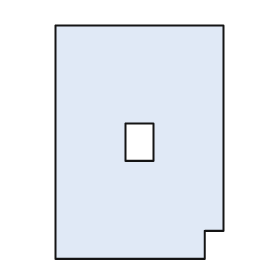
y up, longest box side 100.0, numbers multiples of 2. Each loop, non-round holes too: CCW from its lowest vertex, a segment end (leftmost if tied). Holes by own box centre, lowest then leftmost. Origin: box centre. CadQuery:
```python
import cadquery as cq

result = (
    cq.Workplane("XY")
    .moveTo(-36.0, -50.0)
    .lineTo(28.0, -50.0)
    .lineTo(28.0, -38.0)
    .lineTo(36.0, -38.0)
    .lineTo(36.0, 50.0)
    .lineTo(-36.0, 50.0)
    .close()
    .moveTo(-6.0, -8.0)
    .lineTo(6.0, -8.0)
    .lineTo(6.0, 8.0)
    .lineTo(-6.0, 8.0)
    .close()
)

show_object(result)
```